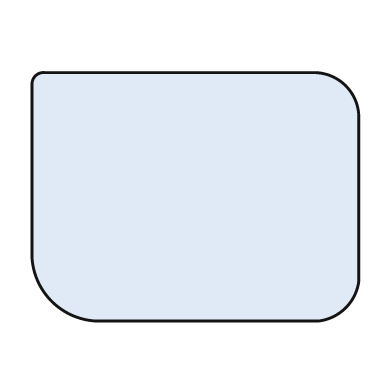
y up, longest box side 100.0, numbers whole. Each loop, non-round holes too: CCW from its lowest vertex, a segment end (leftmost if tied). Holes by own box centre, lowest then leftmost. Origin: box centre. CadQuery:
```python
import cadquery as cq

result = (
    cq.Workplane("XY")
    .moveTo(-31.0, -38.0)
    .lineTo(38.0, -38.0)
    .threePointArc((46.0, -34.0), (50.0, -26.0))
    .lineTo(50.0, 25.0)
    .threePointArc((46.0, 34.0), (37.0, 38.0))
    .lineTo(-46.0, 38.0)
    .threePointArc((-49.0, 37.0), (-50.0, 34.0))
    .lineTo(-50.0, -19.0)
    .threePointArc((-44.0, -32.0), (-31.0, -38.0))
    .close()
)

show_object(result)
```